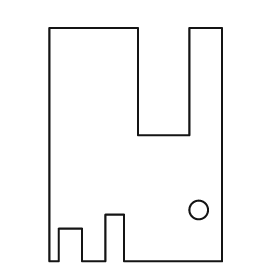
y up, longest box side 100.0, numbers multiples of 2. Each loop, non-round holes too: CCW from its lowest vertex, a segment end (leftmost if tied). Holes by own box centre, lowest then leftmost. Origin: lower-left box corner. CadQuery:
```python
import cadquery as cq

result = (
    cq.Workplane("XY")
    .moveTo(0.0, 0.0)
    .lineTo(4.0, 0.0)
    .lineTo(4.0, 14.0)
    .lineTo(14.0, 14.0)
    .lineTo(14.0, 0.0)
    .lineTo(24.0, 0.0)
    .lineTo(24.0, 20.0)
    .lineTo(32.0, 20.0)
    .lineTo(32.0, 0.0)
    .lineTo(74.0, 0.0)
    .lineTo(74.0, 100.0)
    .lineTo(60.0, 100.0)
    .lineTo(60.0, 54.0)
    .lineTo(38.0, 54.0)
    .lineTo(38.0, 100.0)
    .lineTo(0.0, 100.0)
    .close()
    .moveTo(64.0, 22.0)
    .circle(4.0)
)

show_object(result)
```